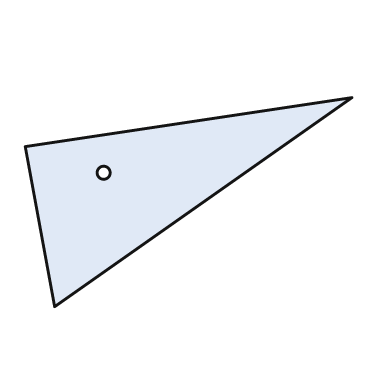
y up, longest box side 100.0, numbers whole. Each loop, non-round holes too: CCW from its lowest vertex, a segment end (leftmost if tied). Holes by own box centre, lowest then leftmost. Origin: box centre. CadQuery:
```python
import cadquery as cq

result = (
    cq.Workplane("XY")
    .moveTo(-41.0, -32.0)
    .lineTo(50.0, 32.0)
    .lineTo(-50.0, 17.0)
    .close()
    .moveTo(-26.0, 9.0)
    .circle(2.0)
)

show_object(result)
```